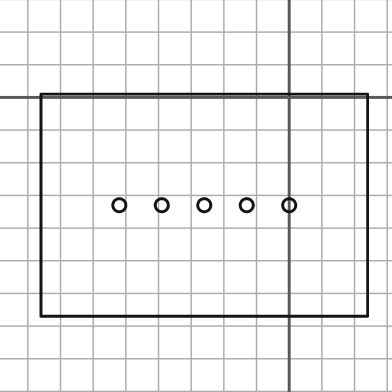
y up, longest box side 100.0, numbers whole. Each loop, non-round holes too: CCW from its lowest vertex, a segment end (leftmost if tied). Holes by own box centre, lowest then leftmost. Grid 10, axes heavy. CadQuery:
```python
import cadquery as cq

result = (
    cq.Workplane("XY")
    .moveTo(-76.0, -67.0)
    .lineTo(24.0, -67.0)
    .lineTo(24.0, 1.0)
    .lineTo(-76.0, 1.0)
    .close()
    .moveTo(-52.0, -33.0)
    .circle(2.0)
    .moveTo(-39.0, -33.0)
    .circle(2.0)
    .moveTo(-26.0, -33.0)
    .circle(2.0)
    .moveTo(-13.0, -33.0)
    .circle(2.0)
    .moveTo(0.0, -33.0)
    .circle(2.0)
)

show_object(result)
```